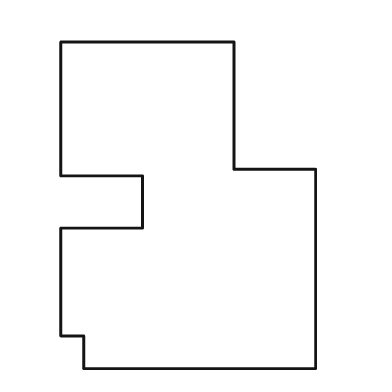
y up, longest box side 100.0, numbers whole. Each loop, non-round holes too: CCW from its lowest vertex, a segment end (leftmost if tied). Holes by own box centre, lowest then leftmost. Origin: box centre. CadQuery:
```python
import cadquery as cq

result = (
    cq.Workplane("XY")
    .moveTo(-32.0, -50.0)
    .lineTo(39.0, -50.0)
    .lineTo(39.0, 11.0)
    .lineTo(14.0, 11.0)
    .lineTo(14.0, 50.0)
    .lineTo(-39.0, 50.0)
    .lineTo(-39.0, 9.0)
    .lineTo(-14.0, 9.0)
    .lineTo(-14.0, -7.0)
    .lineTo(-39.0, -7.0)
    .lineTo(-39.0, -40.0)
    .lineTo(-32.0, -40.0)
    .close()
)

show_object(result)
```